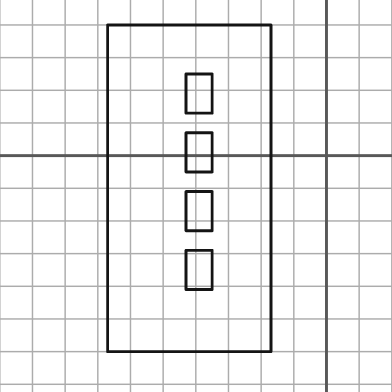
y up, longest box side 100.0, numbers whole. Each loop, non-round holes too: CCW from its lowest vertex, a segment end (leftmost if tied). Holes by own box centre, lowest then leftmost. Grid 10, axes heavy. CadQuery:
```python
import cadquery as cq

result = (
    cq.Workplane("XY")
    .moveTo(-67.0, -60.0)
    .lineTo(-17.0, -60.0)
    .lineTo(-17.0, 40.0)
    .lineTo(-67.0, 40.0)
    .close()
    .moveTo(-43.0, -41.0)
    .lineTo(-35.0, -41.0)
    .lineTo(-35.0, -29.0)
    .lineTo(-43.0, -29.0)
    .close()
    .moveTo(-43.0, -23.0)
    .lineTo(-35.0, -23.0)
    .lineTo(-35.0, -11.0)
    .lineTo(-43.0, -11.0)
    .close()
    .moveTo(-43.0, -5.0)
    .lineTo(-35.0, -5.0)
    .lineTo(-35.0, 7.0)
    .lineTo(-43.0, 7.0)
    .close()
    .moveTo(-43.0, 13.0)
    .lineTo(-35.0, 13.0)
    .lineTo(-35.0, 25.0)
    .lineTo(-43.0, 25.0)
    .close()
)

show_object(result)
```